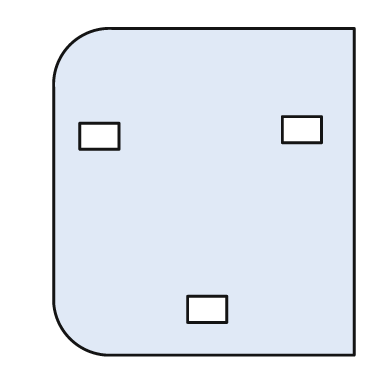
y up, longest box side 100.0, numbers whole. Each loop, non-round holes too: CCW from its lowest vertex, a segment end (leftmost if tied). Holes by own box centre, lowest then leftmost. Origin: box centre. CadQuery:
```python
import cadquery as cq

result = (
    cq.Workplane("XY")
    .moveTo(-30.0, -50.0)
    .lineTo(46.0, -50.0)
    .lineTo(46.0, 50.0)
    .lineTo(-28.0, 50.0)
    .threePointArc((-41.0, 45.0), (-46.0, 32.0))
    .lineTo(-46.0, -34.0)
    .threePointArc((-41.0, -45.0), (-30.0, -50.0))
    .close()
    .moveTo(-5.0, -40.0)
    .lineTo(7.0, -40.0)
    .lineTo(7.0, -32.0)
    .lineTo(-5.0, -32.0)
    .close()
    .moveTo(-38.0, 13.0)
    .lineTo(-26.0, 13.0)
    .lineTo(-26.0, 21.0)
    .lineTo(-38.0, 21.0)
    .close()
    .moveTo(24.0, 15.0)
    .lineTo(36.0, 15.0)
    .lineTo(36.0, 23.0)
    .lineTo(24.0, 23.0)
    .close()
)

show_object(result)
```